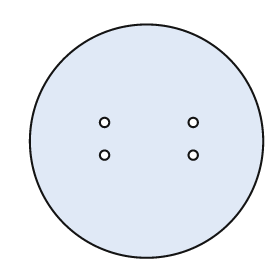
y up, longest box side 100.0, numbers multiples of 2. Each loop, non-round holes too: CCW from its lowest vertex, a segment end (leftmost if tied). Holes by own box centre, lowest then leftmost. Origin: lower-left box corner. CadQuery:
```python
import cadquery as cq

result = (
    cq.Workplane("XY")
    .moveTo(50.0, 50.0)
    .circle(50.0)
    .moveTo(32.0, 44.0)
    .circle(2.0)
    .moveTo(70.0, 44.0)
    .circle(2.0)
    .moveTo(32.0, 58.0)
    .circle(2.0)
    .moveTo(70.0, 58.0)
    .circle(2.0)
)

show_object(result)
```